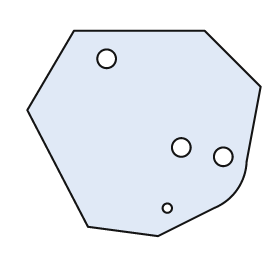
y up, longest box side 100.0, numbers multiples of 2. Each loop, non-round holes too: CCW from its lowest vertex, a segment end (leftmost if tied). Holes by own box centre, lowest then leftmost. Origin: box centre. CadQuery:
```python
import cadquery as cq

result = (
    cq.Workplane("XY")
    .moveTo(6.0, -44.0)
    .lineTo(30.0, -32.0)
    .threePointArc((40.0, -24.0), (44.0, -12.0))
    .lineTo(50.0, 20.0)
    .lineTo(26.0, 44.0)
    .lineTo(-30.0, 44.0)
    .lineTo(-50.0, 10.0)
    .lineTo(-24.0, -40.0)
    .close()
    .moveTo(10.0, -32.0)
    .circle(2.0)
    .moveTo(34.0, -10.0)
    .circle(4.0)
    .moveTo(16.0, -6.0)
    .circle(4.0)
    .moveTo(-16.0, 32.0)
    .circle(4.0)
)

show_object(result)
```